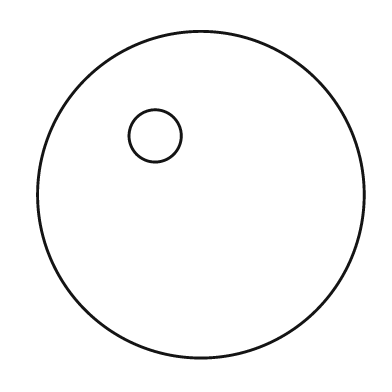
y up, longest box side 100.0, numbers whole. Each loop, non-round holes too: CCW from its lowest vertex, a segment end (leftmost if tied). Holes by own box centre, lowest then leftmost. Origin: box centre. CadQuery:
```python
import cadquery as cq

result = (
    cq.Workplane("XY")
    .moveTo(0.0, 0.0)
    .circle(50.0)
    .moveTo(-14.0, 18.0)
    .circle(8.0)
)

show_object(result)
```